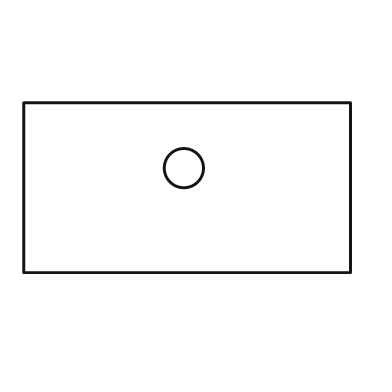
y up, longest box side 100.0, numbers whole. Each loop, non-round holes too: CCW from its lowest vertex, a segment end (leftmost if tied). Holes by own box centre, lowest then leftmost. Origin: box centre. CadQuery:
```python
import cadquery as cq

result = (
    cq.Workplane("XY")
    .moveTo(-50.0, -26.0)
    .lineTo(50.0, -26.0)
    .lineTo(50.0, 26.0)
    .lineTo(-50.0, 26.0)
    .close()
    .moveTo(-1.0, 6.0)
    .circle(6.0)
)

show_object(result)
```